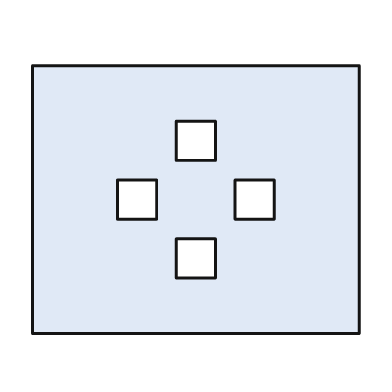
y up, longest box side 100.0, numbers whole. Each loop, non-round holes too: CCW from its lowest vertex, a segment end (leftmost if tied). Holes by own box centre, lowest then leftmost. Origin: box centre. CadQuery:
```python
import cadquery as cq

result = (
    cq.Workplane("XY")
    .moveTo(-50.0, -41.0)
    .lineTo(50.0, -41.0)
    .lineTo(50.0, 41.0)
    .lineTo(-50.0, 41.0)
    .close()
    .moveTo(-6.0, -24.0)
    .lineTo(6.0, -24.0)
    .lineTo(6.0, -12.0)
    .lineTo(-6.0, -12.0)
    .close()
    .moveTo(-24.0, -6.0)
    .lineTo(-12.0, -6.0)
    .lineTo(-12.0, 6.0)
    .lineTo(-24.0, 6.0)
    .close()
    .moveTo(12.0, -6.0)
    .lineTo(24.0, -6.0)
    .lineTo(24.0, 6.0)
    .lineTo(12.0, 6.0)
    .close()
    .moveTo(-6.0, 12.0)
    .lineTo(6.0, 12.0)
    .lineTo(6.0, 24.0)
    .lineTo(-6.0, 24.0)
    .close()
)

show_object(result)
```